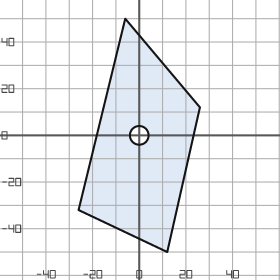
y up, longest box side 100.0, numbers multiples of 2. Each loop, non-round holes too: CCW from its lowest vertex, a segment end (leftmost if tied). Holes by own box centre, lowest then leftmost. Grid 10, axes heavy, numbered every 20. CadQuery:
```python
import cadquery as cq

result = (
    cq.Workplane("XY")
    .moveTo(12.0, -50.0)
    .lineTo(26.0, 12.0)
    .lineTo(-6.0, 50.0)
    .lineTo(-26.0, -32.0)
    .close()
    .moveTo(0.0, 0.0)
    .circle(4.0)
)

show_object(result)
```